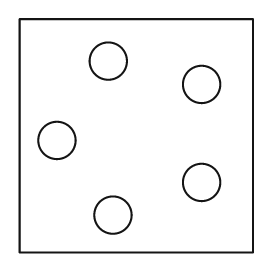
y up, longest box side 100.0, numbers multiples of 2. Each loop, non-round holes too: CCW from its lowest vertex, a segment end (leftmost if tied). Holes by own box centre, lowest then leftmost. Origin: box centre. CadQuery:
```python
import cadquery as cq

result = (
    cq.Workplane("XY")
    .moveTo(-50.0, -50.0)
    .lineTo(50.0, -50.0)
    .lineTo(50.0, 50.0)
    .lineTo(-50.0, 50.0)
    .close()
    .moveTo(-10.0, -34.0)
    .circle(8.0)
    .moveTo(28.0, -20.0)
    .circle(8.0)
    .moveTo(-34.0, -2.0)
    .circle(8.0)
    .moveTo(28.0, 22.0)
    .circle(8.0)
    .moveTo(-12.0, 32.0)
    .circle(8.0)
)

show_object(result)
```